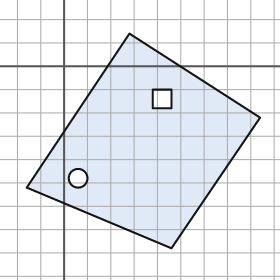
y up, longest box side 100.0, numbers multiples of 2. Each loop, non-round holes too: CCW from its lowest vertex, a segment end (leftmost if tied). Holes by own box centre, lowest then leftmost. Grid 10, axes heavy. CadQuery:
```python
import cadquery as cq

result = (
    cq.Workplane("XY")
    .moveTo(46.0, -78.0)
    .lineTo(84.0, -22.0)
    .lineTo(28.0, 14.0)
    .lineTo(-16.0, -52.0)
    .close()
    .moveTo(6.0, -48.0)
    .circle(4.0)
    .moveTo(38.0, -18.0)
    .lineTo(46.0, -18.0)
    .lineTo(46.0, -10.0)
    .lineTo(38.0, -10.0)
    .close()
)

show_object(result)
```